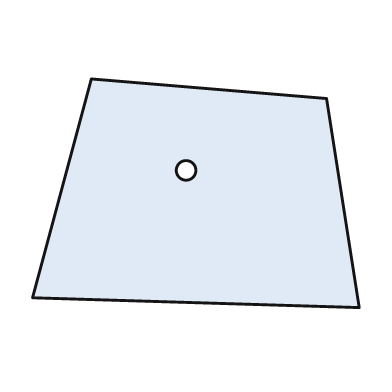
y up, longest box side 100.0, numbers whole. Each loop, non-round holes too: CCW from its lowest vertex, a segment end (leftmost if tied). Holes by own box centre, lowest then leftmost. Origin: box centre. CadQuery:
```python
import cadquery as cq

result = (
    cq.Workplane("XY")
    .moveTo(50.0, -35.0)
    .lineTo(40.0, 29.0)
    .lineTo(-32.0, 35.0)
    .lineTo(-50.0, -32.0)
    .close()
    .moveTo(-3.0, 7.0)
    .circle(3.0)
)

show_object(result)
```